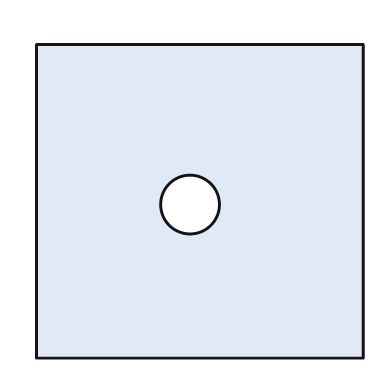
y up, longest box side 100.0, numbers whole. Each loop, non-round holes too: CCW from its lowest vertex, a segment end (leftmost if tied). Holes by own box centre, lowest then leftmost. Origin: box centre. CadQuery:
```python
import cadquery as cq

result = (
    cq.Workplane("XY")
    .moveTo(-50.0, -48.0)
    .lineTo(50.0, -48.0)
    .lineTo(50.0, 48.0)
    .lineTo(-50.0, 48.0)
    .close()
    .moveTo(-3.0, -1.0)
    .circle(9.0)
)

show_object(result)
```